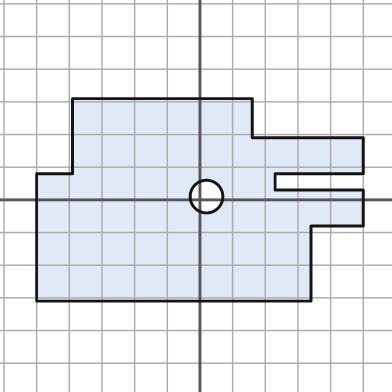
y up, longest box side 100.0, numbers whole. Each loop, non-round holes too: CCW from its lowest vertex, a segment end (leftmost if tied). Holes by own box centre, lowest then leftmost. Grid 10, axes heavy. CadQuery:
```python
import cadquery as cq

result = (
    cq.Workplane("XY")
    .moveTo(-50.0, -31.0)
    .lineTo(34.0, -31.0)
    .lineTo(34.0, -8.0)
    .lineTo(50.0, -8.0)
    .lineTo(50.0, 3.0)
    .lineTo(23.0, 3.0)
    .lineTo(23.0, 8.0)
    .lineTo(50.0, 8.0)
    .lineTo(50.0, 19.0)
    .lineTo(16.0, 19.0)
    .lineTo(16.0, 31.0)
    .lineTo(-39.0, 31.0)
    .lineTo(-39.0, 8.0)
    .lineTo(-50.0, 8.0)
    .close()
    .moveTo(2.0, 1.0)
    .circle(5.0)
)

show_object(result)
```